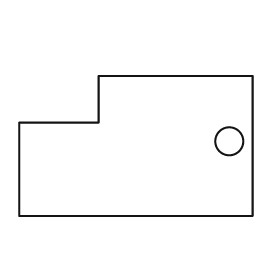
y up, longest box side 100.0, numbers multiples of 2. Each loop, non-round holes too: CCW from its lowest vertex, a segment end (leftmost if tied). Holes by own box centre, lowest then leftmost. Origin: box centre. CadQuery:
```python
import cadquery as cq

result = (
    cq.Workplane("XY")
    .moveTo(-50.0, -30.0)
    .lineTo(50.0, -30.0)
    .lineTo(50.0, 30.0)
    .lineTo(-16.0, 30.0)
    .lineTo(-16.0, 10.0)
    .lineTo(-50.0, 10.0)
    .close()
    .moveTo(40.0, 2.0)
    .circle(6.0)
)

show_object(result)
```